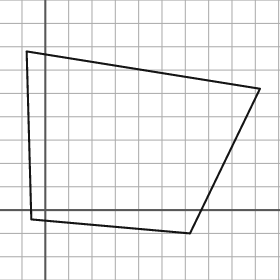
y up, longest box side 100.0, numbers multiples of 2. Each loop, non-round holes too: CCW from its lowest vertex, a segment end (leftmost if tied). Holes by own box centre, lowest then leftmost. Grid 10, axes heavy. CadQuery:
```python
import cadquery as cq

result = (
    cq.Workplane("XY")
    .moveTo(62.0, -10.0)
    .lineTo(92.0, 52.0)
    .lineTo(-8.0, 68.0)
    .lineTo(-6.0, -4.0)
    .close()
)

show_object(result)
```